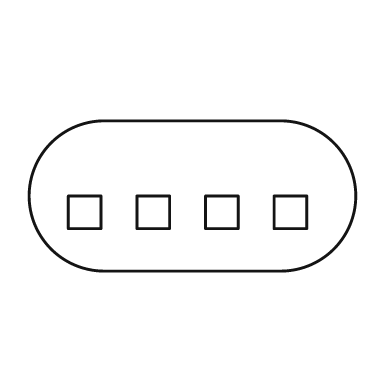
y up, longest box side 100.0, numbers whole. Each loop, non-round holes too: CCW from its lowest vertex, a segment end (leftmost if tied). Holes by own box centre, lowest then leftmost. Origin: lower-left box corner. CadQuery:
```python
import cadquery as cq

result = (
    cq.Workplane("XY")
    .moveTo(23.0, 0.0)
    .lineTo(77.0, 0.0)
    .threePointArc((100.0, 23.0), (77.0, 46.0))
    .lineTo(23.0, 46.0)
    .threePointArc((0.0, 23.0), (23.0, 0.0))
    .close()
    .moveTo(12.0, 13.0)
    .lineTo(22.0, 13.0)
    .lineTo(22.0, 23.0)
    .lineTo(12.0, 23.0)
    .close()
    .moveTo(33.0, 13.0)
    .lineTo(43.0, 13.0)
    .lineTo(43.0, 23.0)
    .lineTo(33.0, 23.0)
    .close()
    .moveTo(54.0, 13.0)
    .lineTo(64.0, 13.0)
    .lineTo(64.0, 23.0)
    .lineTo(54.0, 23.0)
    .close()
    .moveTo(75.0, 13.0)
    .lineTo(85.0, 13.0)
    .lineTo(85.0, 23.0)
    .lineTo(75.0, 23.0)
    .close()
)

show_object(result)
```